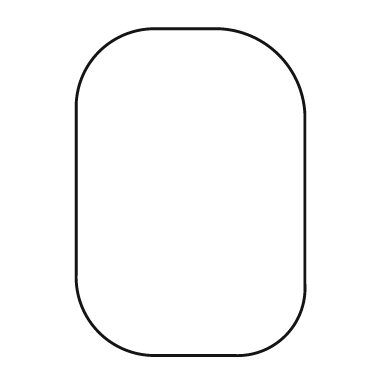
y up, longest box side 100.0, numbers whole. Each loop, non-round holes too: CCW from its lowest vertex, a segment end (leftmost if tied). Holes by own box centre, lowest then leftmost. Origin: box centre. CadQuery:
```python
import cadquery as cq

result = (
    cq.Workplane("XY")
    .moveTo(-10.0, -50.0)
    .lineTo(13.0, -50.0)
    .threePointArc((29.0, -44.0), (35.0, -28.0))
    .lineTo(35.0, 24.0)
    .threePointArc((27.0, 42.0), (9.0, 50.0))
    .lineTo(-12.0, 50.0)
    .threePointArc((-28.0, 43.0), (-35.0, 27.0))
    .lineTo(-35.0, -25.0)
    .threePointArc((-28.0, -43.0), (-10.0, -50.0))
    .close()
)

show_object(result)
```